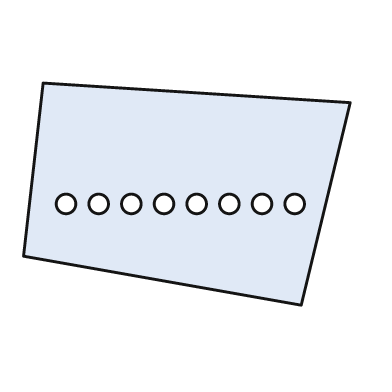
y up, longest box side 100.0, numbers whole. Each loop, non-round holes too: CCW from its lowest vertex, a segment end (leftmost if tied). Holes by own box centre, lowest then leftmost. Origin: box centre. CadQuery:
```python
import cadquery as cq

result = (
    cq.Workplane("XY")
    .moveTo(35.0, -34.0)
    .lineTo(50.0, 28.0)
    .lineTo(-44.0, 34.0)
    .lineTo(-50.0, -19.0)
    .close()
    .moveTo(-37.0, -3.0)
    .circle(3.0)
    .moveTo(-27.0, -3.0)
    .circle(3.0)
    .moveTo(-17.0, -3.0)
    .circle(3.0)
    .moveTo(-7.0, -3.0)
    .circle(3.0)
    .moveTo(3.0, -3.0)
    .circle(3.0)
    .moveTo(13.0, -3.0)
    .circle(3.0)
    .moveTo(23.0, -3.0)
    .circle(3.0)
    .moveTo(33.0, -3.0)
    .circle(3.0)
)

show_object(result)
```